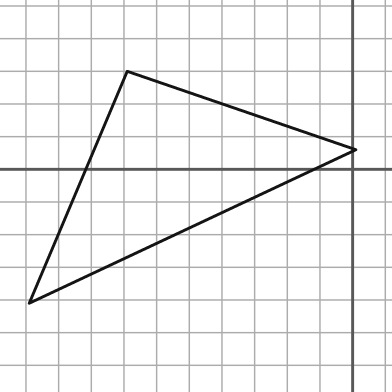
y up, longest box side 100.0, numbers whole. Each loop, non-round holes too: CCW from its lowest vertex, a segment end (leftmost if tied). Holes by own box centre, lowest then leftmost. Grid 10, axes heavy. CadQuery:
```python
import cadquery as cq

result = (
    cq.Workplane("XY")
    .moveTo(-99.0, -41.0)
    .lineTo(1.0, 6.0)
    .lineTo(-69.0, 30.0)
    .close()
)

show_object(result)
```